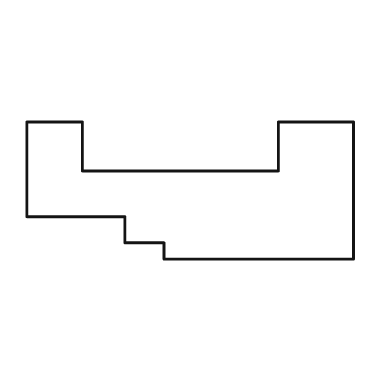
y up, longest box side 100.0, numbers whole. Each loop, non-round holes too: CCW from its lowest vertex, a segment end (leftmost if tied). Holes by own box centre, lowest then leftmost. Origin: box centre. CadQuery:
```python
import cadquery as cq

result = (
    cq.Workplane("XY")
    .moveTo(-8.0, -21.0)
    .lineTo(50.0, -21.0)
    .lineTo(50.0, 21.0)
    .lineTo(27.0, 21.0)
    .lineTo(27.0, 6.0)
    .lineTo(-33.0, 6.0)
    .lineTo(-33.0, 21.0)
    .lineTo(-50.0, 21.0)
    .lineTo(-50.0, -8.0)
    .lineTo(-20.0, -8.0)
    .lineTo(-20.0, -16.0)
    .lineTo(-8.0, -16.0)
    .close()
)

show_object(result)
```